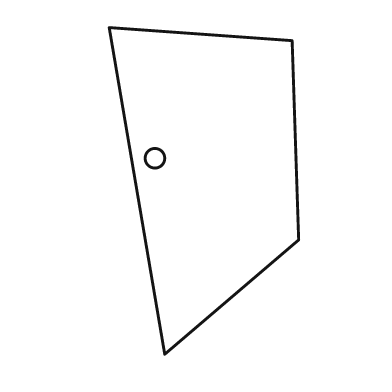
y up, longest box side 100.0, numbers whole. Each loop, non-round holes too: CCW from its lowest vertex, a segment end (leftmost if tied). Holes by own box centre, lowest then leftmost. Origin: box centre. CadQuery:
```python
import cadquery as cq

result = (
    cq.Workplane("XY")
    .moveTo(-12.0, -50.0)
    .lineTo(29.0, -15.0)
    .lineTo(27.0, 46.0)
    .lineTo(-29.0, 50.0)
    .close()
    .moveTo(-15.0, 10.0)
    .circle(3.0)
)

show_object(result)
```